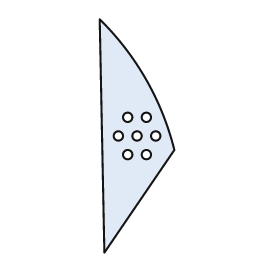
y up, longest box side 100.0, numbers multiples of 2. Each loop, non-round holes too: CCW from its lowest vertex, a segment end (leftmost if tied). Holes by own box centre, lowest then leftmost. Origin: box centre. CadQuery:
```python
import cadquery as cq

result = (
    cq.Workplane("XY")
    .moveTo(-14.0, -50.0)
    .lineTo(16.0, -6.0)
    .threePointArc((4.0, 24.0), (-16.0, 50.0))
    .close()
    .moveTo(-4.0, -8.0)
    .circle(2.0)
    .moveTo(4.0, -8.0)
    .circle(2.0)
    .moveTo(-8.0, 0.0)
    .circle(2.0)
    .moveTo(0.0, 0.0)
    .circle(2.0)
    .moveTo(8.0, 0.0)
    .circle(2.0)
    .moveTo(-4.0, 8.0)
    .circle(2.0)
    .moveTo(4.0, 8.0)
    .circle(2.0)
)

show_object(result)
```